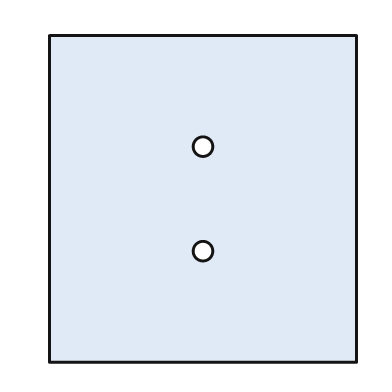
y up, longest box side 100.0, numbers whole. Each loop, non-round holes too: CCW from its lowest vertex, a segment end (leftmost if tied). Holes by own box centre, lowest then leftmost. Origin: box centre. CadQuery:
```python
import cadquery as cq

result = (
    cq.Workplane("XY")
    .moveTo(-47.0, -50.0)
    .lineTo(47.0, -50.0)
    .lineTo(47.0, 50.0)
    .lineTo(-47.0, 50.0)
    .close()
    .moveTo(0.0, -16.0)
    .circle(3.0)
    .moveTo(0.0, 16.0)
    .circle(3.0)
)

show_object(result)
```